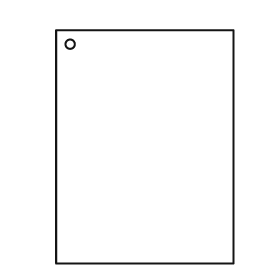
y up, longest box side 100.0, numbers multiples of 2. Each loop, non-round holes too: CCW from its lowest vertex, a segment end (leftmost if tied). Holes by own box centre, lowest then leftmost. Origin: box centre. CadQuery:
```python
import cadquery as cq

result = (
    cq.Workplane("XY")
    .moveTo(-38.0, -50.0)
    .lineTo(38.0, -50.0)
    .lineTo(38.0, 50.0)
    .lineTo(-38.0, 50.0)
    .close()
    .moveTo(-32.0, 44.0)
    .circle(2.0)
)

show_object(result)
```